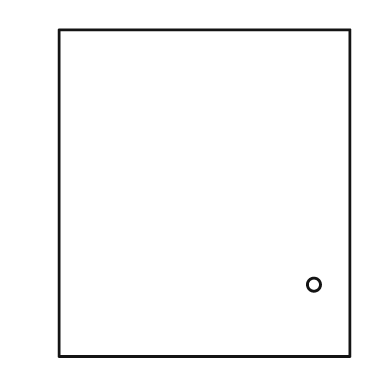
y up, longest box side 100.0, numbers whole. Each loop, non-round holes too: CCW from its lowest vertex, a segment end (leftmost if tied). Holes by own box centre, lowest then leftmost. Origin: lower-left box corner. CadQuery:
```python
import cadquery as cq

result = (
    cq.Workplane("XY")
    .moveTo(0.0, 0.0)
    .lineTo(89.0, 0.0)
    .lineTo(89.0, 100.0)
    .lineTo(0.0, 100.0)
    .close()
    .moveTo(78.0, 22.0)
    .circle(2.0)
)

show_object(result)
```